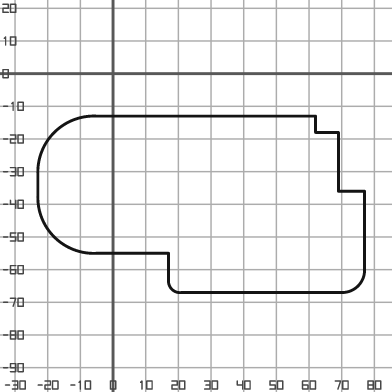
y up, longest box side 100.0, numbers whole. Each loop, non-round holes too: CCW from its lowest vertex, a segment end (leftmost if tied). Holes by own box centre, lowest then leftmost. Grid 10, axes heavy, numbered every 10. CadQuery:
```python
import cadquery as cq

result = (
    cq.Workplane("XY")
    .moveTo(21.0, -67.0)
    .lineTo(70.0, -67.0)
    .threePointArc((75.0, -65.0), (77.0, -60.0))
    .lineTo(77.0, -36.0)
    .lineTo(69.0, -36.0)
    .lineTo(69.0, -18.0)
    .lineTo(62.0, -18.0)
    .lineTo(62.0, -13.0)
    .lineTo(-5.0, -13.0)
    .threePointArc((-18.0, -18.0), (-23.0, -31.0))
    .lineTo(-23.0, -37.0)
    .threePointArc((-18.0, -50.0), (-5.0, -55.0))
    .lineTo(17.0, -55.0)
    .lineTo(17.0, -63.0)
    .threePointArc((18.0, -66.0), (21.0, -67.0))
    .close()
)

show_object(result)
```